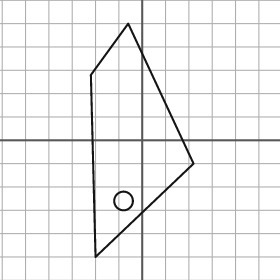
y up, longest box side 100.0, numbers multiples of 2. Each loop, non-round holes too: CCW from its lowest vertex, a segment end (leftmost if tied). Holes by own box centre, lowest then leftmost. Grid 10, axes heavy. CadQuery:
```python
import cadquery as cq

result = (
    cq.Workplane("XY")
    .moveTo(-20.0, -50.0)
    .lineTo(22.0, -10.0)
    .lineTo(-6.0, 50.0)
    .lineTo(-22.0, 28.0)
    .close()
    .moveTo(-8.0, -26.0)
    .circle(4.0)
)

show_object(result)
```